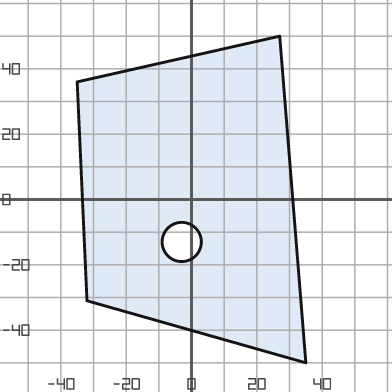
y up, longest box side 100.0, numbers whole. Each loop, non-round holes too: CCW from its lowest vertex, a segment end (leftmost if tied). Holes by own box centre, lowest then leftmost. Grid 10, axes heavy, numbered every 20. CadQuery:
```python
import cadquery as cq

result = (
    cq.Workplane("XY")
    .moveTo(35.0, -50.0)
    .lineTo(27.0, 50.0)
    .lineTo(-35.0, 36.0)
    .lineTo(-32.0, -31.0)
    .close()
    .moveTo(-3.0, -13.0)
    .circle(6.0)
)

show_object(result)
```